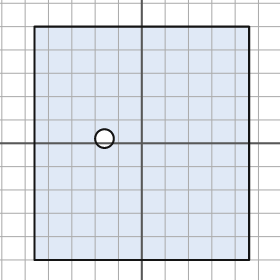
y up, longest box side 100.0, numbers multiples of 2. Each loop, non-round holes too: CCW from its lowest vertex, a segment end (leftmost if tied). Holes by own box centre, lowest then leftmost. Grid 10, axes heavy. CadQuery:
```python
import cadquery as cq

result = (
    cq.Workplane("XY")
    .moveTo(-46.0, -50.0)
    .lineTo(46.0, -50.0)
    .lineTo(46.0, 50.0)
    .lineTo(-46.0, 50.0)
    .close()
    .moveTo(-16.0, 2.0)
    .circle(4.0)
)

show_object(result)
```